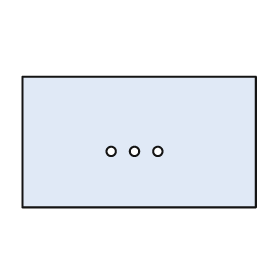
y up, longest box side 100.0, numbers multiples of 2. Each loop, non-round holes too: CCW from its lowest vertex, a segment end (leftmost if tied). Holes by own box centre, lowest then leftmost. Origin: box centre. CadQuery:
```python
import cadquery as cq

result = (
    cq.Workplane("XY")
    .moveTo(-50.0, -28.0)
    .lineTo(50.0, -28.0)
    .lineTo(50.0, 28.0)
    .lineTo(-50.0, 28.0)
    .close()
    .moveTo(-12.0, -4.0)
    .circle(2.0)
    .moveTo(-2.0, -4.0)
    .circle(2.0)
    .moveTo(8.0, -4.0)
    .circle(2.0)
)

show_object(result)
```